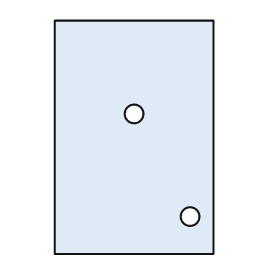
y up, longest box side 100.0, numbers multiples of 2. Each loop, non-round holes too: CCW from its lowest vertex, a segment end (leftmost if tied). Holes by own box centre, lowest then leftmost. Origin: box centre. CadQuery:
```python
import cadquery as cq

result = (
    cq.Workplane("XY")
    .moveTo(-34.0, -50.0)
    .lineTo(34.0, -50.0)
    .lineTo(34.0, 50.0)
    .lineTo(-34.0, 50.0)
    .close()
    .moveTo(24.0, -34.0)
    .circle(4.0)
    .moveTo(0.0, 10.0)
    .circle(4.0)
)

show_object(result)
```